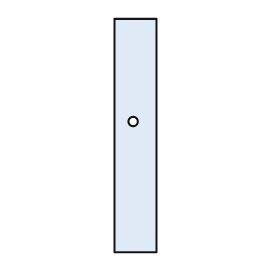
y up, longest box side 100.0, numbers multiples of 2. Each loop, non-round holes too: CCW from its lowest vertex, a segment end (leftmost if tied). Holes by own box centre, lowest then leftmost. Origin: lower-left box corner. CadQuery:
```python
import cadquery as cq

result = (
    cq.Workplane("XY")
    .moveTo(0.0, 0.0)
    .lineTo(18.0, 0.0)
    .lineTo(18.0, 100.0)
    .lineTo(0.0, 100.0)
    .close()
    .moveTo(8.0, 56.0)
    .circle(2.0)
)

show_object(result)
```